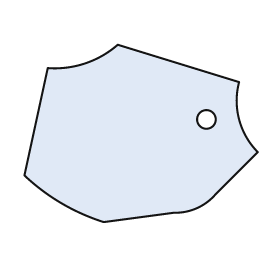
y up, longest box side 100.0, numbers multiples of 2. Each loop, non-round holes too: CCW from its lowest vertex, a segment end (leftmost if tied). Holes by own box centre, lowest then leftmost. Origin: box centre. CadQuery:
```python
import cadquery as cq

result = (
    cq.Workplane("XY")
    .moveTo(-16.0, -38.0)
    .lineTo(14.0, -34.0)
    .threePointArc((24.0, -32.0), (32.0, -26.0))
    .lineTo(50.0, -8.0)
    .threePointArc((42.0, 6.0), (42.0, 22.0))
    .lineTo(-10.0, 38.0)
    .threePointArc((-24.0, 30.0), (-40.0, 28.0))
    .lineTo(-50.0, -18.0)
    .threePointArc((-34.0, -30.0), (-16.0, -38.0))
    .close()
    .moveTo(28.0, 6.0)
    .circle(4.0)
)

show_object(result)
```